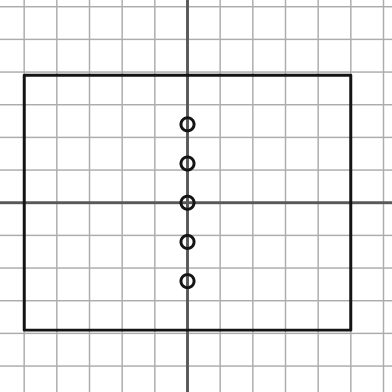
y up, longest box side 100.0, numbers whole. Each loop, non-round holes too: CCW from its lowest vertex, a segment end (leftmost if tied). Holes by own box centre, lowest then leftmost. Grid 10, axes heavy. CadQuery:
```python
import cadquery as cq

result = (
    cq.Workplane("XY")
    .moveTo(-50.0, -39.0)
    .lineTo(50.0, -39.0)
    .lineTo(50.0, 39.0)
    .lineTo(-50.0, 39.0)
    .close()
    .moveTo(0.0, -24.0)
    .circle(2.0)
    .moveTo(0.0, -12.0)
    .circle(2.0)
    .moveTo(0.0, 0.0)
    .circle(2.0)
    .moveTo(0.0, 12.0)
    .circle(2.0)
    .moveTo(0.0, 24.0)
    .circle(2.0)
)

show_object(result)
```